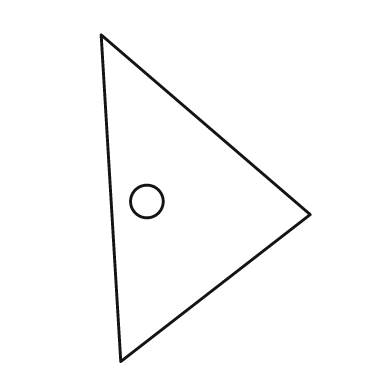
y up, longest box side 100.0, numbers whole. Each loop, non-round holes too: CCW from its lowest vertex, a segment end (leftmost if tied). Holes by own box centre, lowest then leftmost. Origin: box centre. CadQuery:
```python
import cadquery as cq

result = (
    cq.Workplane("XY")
    .moveTo(-26.0, -50.0)
    .lineTo(32.0, -5.0)
    .lineTo(-32.0, 50.0)
    .close()
    .moveTo(-18.0, -1.0)
    .circle(5.0)
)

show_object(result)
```